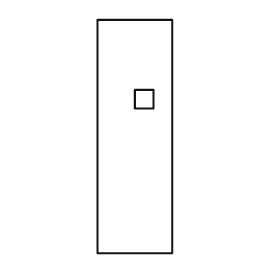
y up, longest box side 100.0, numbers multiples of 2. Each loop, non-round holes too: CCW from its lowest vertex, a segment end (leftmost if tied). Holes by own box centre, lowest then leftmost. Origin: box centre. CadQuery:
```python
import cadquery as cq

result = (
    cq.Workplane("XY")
    .moveTo(-16.0, -50.0)
    .lineTo(16.0, -50.0)
    .lineTo(16.0, 50.0)
    .lineTo(-16.0, 50.0)
    .close()
    .moveTo(0.0, 12.0)
    .lineTo(8.0, 12.0)
    .lineTo(8.0, 20.0)
    .lineTo(0.0, 20.0)
    .close()
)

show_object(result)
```